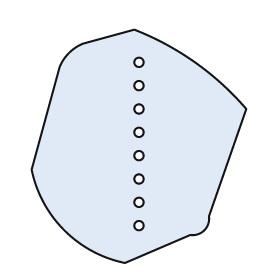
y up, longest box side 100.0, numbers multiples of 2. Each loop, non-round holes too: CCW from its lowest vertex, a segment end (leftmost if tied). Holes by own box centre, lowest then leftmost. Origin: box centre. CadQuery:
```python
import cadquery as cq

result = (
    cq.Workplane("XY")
    .moveTo(-6.0, -50.0)
    .lineTo(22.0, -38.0)
    .threePointArc((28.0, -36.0), (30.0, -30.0))
    .lineTo(46.0, 16.0)
    .threePointArc((24.0, 36.0), (-2.0, 50.0))
    .lineTo(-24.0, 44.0)
    .threePointArc((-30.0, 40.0), (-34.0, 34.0))
    .lineTo(-46.0, -10.0)
    .threePointArc((-32.0, -36.0), (-6.0, -50.0))
    .close()
    .moveTo(0.0, -34.0)
    .circle(2.0)
    .moveTo(0.0, -24.0)
    .circle(2.0)
    .moveTo(0.0, -14.0)
    .circle(2.0)
    .moveTo(0.0, -4.0)
    .circle(2.0)
    .moveTo(0.0, 6.0)
    .circle(2.0)
    .moveTo(0.0, 16.0)
    .circle(2.0)
    .moveTo(0.0, 26.0)
    .circle(2.0)
    .moveTo(0.0, 36.0)
    .circle(2.0)
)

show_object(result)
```